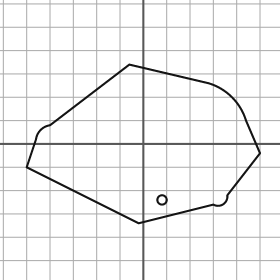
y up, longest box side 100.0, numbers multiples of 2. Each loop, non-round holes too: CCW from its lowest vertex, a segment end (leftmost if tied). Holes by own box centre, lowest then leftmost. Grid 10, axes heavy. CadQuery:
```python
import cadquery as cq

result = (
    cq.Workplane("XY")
    .moveTo(-2.0, -34.0)
    .lineTo(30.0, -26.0)
    .threePointArc((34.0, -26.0), (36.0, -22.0))
    .lineTo(50.0, -4.0)
    .lineTo(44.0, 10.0)
    .threePointArc((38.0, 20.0), (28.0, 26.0))
    .lineTo(-6.0, 34.0)
    .lineTo(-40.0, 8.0)
    .threePointArc((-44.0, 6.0), (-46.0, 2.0))
    .lineTo(-50.0, -10.0)
    .close()
    .moveTo(8.0, -24.0)
    .circle(2.0)
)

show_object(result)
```